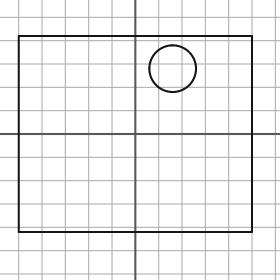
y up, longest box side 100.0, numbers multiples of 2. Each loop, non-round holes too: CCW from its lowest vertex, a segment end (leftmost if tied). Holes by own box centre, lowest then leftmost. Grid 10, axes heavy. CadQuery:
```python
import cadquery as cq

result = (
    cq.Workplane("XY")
    .moveTo(-50.0, -42.0)
    .lineTo(50.0, -42.0)
    .lineTo(50.0, 42.0)
    .lineTo(-50.0, 42.0)
    .close()
    .moveTo(16.0, 28.0)
    .circle(10.0)
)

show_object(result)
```